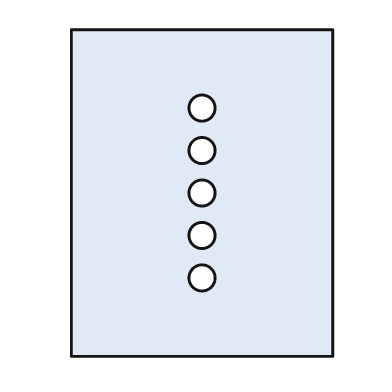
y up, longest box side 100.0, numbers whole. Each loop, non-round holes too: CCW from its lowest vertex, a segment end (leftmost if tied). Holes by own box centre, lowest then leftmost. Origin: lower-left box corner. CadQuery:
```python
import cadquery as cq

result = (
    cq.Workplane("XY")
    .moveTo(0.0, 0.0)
    .lineTo(80.0, 0.0)
    .lineTo(80.0, 100.0)
    .lineTo(0.0, 100.0)
    .close()
    .moveTo(40.0, 24.0)
    .circle(4.0)
    .moveTo(40.0, 37.0)
    .circle(4.0)
    .moveTo(40.0, 50.0)
    .circle(4.0)
    .moveTo(40.0, 63.0)
    .circle(4.0)
    .moveTo(40.0, 76.0)
    .circle(4.0)
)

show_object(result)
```